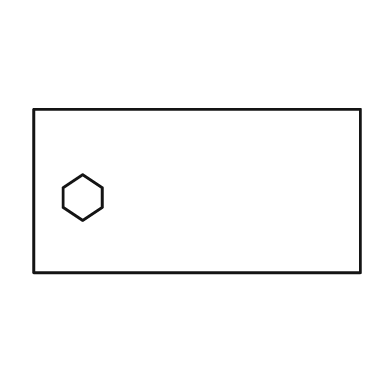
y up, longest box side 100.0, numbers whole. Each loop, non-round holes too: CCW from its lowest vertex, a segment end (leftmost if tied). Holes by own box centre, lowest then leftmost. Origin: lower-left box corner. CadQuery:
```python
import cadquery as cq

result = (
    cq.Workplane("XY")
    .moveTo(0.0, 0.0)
    .lineTo(100.0, 0.0)
    .lineTo(100.0, 50.0)
    .lineTo(0.0, 50.0)
    .close()
    .moveTo(15.0, 16.0)
    .lineTo(21.0, 20.0)
    .lineTo(21.0, 26.0)
    .lineTo(15.0, 30.0)
    .lineTo(9.0, 26.0)
    .lineTo(9.0, 20.0)
    .close()
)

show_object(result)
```